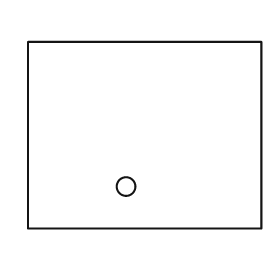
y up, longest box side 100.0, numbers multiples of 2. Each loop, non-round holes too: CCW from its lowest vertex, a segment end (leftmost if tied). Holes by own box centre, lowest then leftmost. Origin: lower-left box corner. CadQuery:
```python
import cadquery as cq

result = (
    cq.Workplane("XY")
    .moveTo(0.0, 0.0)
    .lineTo(100.0, 0.0)
    .lineTo(100.0, 80.0)
    .lineTo(0.0, 80.0)
    .close()
    .moveTo(42.0, 18.0)
    .circle(4.0)
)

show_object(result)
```